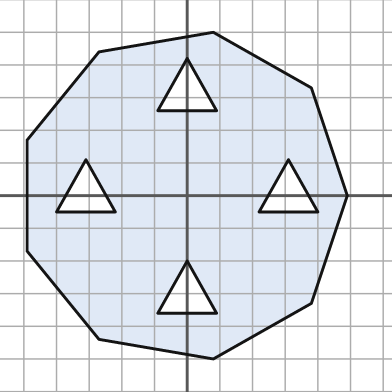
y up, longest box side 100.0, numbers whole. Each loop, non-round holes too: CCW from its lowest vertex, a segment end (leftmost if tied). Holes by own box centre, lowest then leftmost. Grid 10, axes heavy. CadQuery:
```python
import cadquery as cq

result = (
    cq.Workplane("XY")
    .moveTo(8.0, -50.0)
    .lineTo(38.0, -33.0)
    .lineTo(49.0, 0.0)
    .lineTo(38.0, 33.0)
    .lineTo(8.0, 50.0)
    .lineTo(-27.0, 44.0)
    .lineTo(-49.0, 17.0)
    .lineTo(-49.0, -17.0)
    .lineTo(-27.0, -44.0)
    .close()
    .moveTo(-9.0, -36.0)
    .lineTo(9.0, -36.0)
    .lineTo(0.0, -20.0)
    .close()
    .moveTo(-40.0, -5.0)
    .lineTo(-22.0, -5.0)
    .lineTo(-31.0, 11.0)
    .close()
    .moveTo(22.0, -5.0)
    .lineTo(40.0, -5.0)
    .lineTo(31.0, 11.0)
    .close()
    .moveTo(-9.0, 26.0)
    .lineTo(9.0, 26.0)
    .lineTo(0.0, 42.0)
    .close()
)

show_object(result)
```